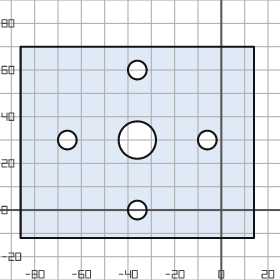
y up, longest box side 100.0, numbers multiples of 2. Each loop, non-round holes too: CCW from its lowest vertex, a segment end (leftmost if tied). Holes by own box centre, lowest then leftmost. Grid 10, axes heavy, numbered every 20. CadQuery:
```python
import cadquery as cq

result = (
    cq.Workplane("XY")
    .moveTo(-86.0, -12.0)
    .lineTo(14.0, -12.0)
    .lineTo(14.0, 70.0)
    .lineTo(-86.0, 70.0)
    .close()
    .moveTo(-36.0, 0.0)
    .circle(4.0)
    .moveTo(-66.0, 30.0)
    .circle(4.0)
    .moveTo(-36.0, 30.0)
    .circle(8.0)
    .moveTo(-6.0, 30.0)
    .circle(4.0)
    .moveTo(-36.0, 60.0)
    .circle(4.0)
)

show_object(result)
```